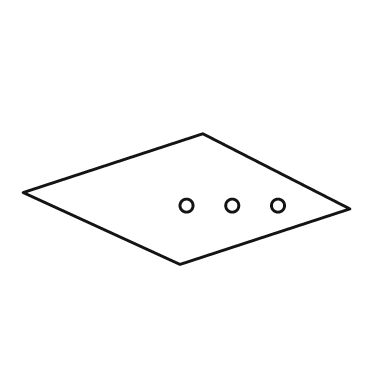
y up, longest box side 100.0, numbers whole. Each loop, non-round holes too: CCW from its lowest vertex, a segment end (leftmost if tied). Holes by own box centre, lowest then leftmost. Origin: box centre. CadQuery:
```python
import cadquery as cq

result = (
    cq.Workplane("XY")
    .moveTo(-2.0, -20.0)
    .lineTo(50.0, -3.0)
    .lineTo(5.0, 20.0)
    .lineTo(-50.0, 2.0)
    .close()
    .moveTo(0.0, -2.0)
    .circle(2.0)
    .moveTo(14.0, -2.0)
    .circle(2.0)
    .moveTo(28.0, -2.0)
    .circle(2.0)
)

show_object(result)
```